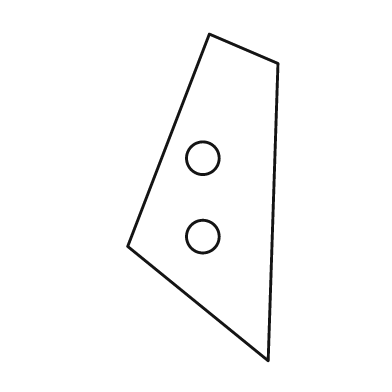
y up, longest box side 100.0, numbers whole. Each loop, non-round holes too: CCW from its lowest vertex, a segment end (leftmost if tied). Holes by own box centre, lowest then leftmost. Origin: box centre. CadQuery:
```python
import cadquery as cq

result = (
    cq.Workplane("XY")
    .moveTo(20.0, -50.0)
    .lineTo(23.0, 41.0)
    .lineTo(2.0, 50.0)
    .lineTo(-23.0, -15.0)
    .close()
    .moveTo(0.0, -12.0)
    .circle(5.0)
    .moveTo(0.0, 12.0)
    .circle(5.0)
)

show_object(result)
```